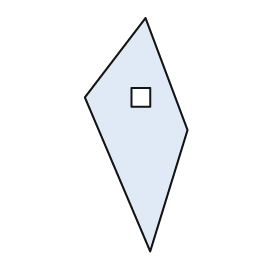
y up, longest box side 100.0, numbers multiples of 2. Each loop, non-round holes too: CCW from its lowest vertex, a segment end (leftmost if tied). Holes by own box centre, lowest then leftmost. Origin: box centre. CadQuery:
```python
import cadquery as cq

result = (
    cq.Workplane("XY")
    .moveTo(6.0, -50.0)
    .lineTo(22.0, 2.0)
    .lineTo(4.0, 50.0)
    .lineTo(-22.0, 16.0)
    .close()
    .moveTo(-2.0, 12.0)
    .lineTo(6.0, 12.0)
    .lineTo(6.0, 20.0)
    .lineTo(-2.0, 20.0)
    .close()
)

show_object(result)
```